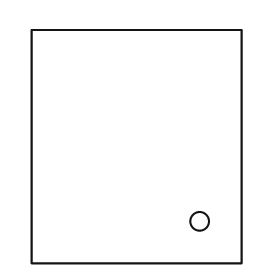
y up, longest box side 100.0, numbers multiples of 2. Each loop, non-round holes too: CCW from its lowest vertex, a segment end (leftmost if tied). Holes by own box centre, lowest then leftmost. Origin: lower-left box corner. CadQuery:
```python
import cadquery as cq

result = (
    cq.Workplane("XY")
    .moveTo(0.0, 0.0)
    .lineTo(90.0, 0.0)
    .lineTo(90.0, 100.0)
    .lineTo(0.0, 100.0)
    .close()
    .moveTo(72.0, 18.0)
    .circle(4.0)
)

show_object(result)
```